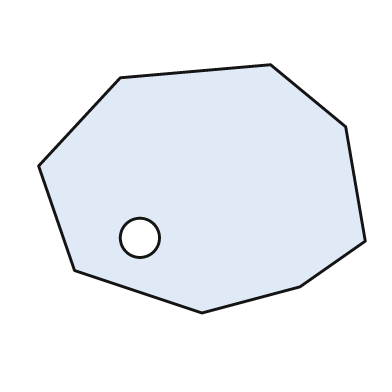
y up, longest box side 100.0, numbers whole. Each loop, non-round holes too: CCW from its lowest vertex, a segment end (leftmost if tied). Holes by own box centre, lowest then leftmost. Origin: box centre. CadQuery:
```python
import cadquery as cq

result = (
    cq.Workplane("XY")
    .moveTo(0.0, -38.0)
    .lineTo(30.0, -30.0)
    .lineTo(50.0, -16.0)
    .lineTo(44.0, 19.0)
    .lineTo(21.0, 38.0)
    .lineTo(-25.0, 34.0)
    .lineTo(-50.0, 7.0)
    .lineTo(-39.0, -25.0)
    .close()
    .moveTo(-19.0, -15.0)
    .circle(6.0)
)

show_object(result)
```